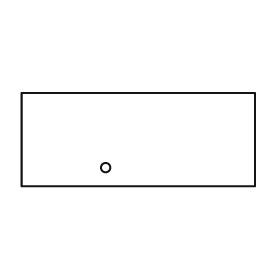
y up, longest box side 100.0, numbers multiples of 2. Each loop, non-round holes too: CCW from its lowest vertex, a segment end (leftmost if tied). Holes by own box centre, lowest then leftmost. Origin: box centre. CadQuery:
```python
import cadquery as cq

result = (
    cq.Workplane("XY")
    .moveTo(-50.0, -20.0)
    .lineTo(50.0, -20.0)
    .lineTo(50.0, 20.0)
    .lineTo(-50.0, 20.0)
    .close()
    .moveTo(-14.0, -12.0)
    .circle(2.0)
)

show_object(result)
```